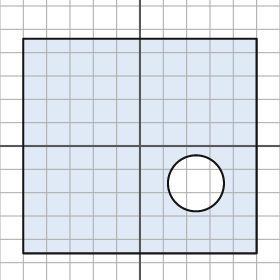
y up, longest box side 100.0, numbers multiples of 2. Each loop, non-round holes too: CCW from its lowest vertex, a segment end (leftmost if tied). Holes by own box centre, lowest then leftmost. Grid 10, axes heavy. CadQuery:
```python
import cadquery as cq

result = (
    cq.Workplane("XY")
    .moveTo(-50.0, -46.0)
    .lineTo(50.0, -46.0)
    .lineTo(50.0, 46.0)
    .lineTo(-50.0, 46.0)
    .close()
    .moveTo(24.0, -16.0)
    .circle(12.0)
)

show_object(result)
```